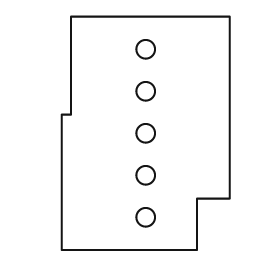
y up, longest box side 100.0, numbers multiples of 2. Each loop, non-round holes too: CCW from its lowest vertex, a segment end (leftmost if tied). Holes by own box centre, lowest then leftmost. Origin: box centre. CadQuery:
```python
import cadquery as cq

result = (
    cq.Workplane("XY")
    .moveTo(-36.0, -50.0)
    .lineTo(22.0, -50.0)
    .lineTo(22.0, -28.0)
    .lineTo(36.0, -28.0)
    .lineTo(36.0, 50.0)
    .lineTo(-32.0, 50.0)
    .lineTo(-32.0, 8.0)
    .lineTo(-36.0, 8.0)
    .close()
    .moveTo(0.0, -36.0)
    .circle(4.0)
    .moveTo(0.0, -18.0)
    .circle(4.0)
    .moveTo(0.0, 0.0)
    .circle(4.0)
    .moveTo(0.0, 18.0)
    .circle(4.0)
    .moveTo(0.0, 36.0)
    .circle(4.0)
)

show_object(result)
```